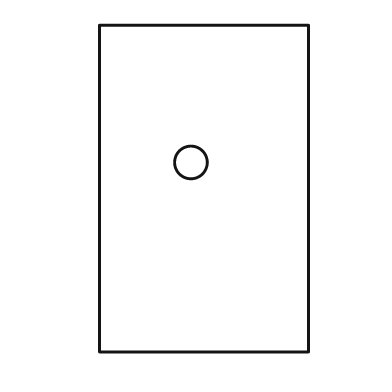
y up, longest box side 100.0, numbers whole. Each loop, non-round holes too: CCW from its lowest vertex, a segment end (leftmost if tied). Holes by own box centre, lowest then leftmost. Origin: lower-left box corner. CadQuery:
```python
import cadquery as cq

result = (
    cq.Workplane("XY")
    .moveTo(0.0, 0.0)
    .lineTo(64.0, 0.0)
    .lineTo(64.0, 100.0)
    .lineTo(0.0, 100.0)
    .close()
    .moveTo(28.0, 58.0)
    .circle(5.0)
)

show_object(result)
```